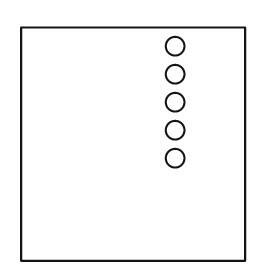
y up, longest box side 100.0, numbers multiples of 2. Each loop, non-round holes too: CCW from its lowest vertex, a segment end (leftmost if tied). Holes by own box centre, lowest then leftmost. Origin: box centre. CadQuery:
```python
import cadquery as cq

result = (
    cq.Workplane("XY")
    .moveTo(-48.0, -50.0)
    .lineTo(48.0, -50.0)
    .lineTo(48.0, 50.0)
    .lineTo(-48.0, 50.0)
    .close()
    .moveTo(18.0, -6.0)
    .circle(4.0)
    .moveTo(18.0, 6.0)
    .circle(4.0)
    .moveTo(18.0, 18.0)
    .circle(4.0)
    .moveTo(18.0, 30.0)
    .circle(4.0)
    .moveTo(18.0, 42.0)
    .circle(4.0)
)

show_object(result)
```